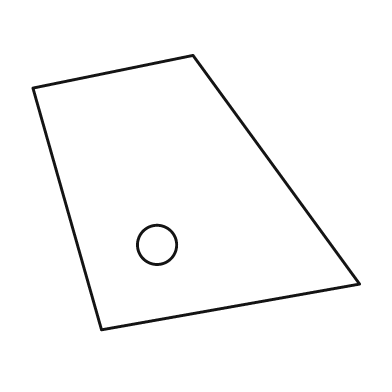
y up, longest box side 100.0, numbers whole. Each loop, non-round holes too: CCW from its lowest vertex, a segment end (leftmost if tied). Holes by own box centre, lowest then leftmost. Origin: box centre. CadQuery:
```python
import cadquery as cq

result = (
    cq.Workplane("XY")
    .moveTo(-29.0, -42.0)
    .lineTo(50.0, -28.0)
    .lineTo(-1.0, 42.0)
    .lineTo(-50.0, 32.0)
    .close()
    .moveTo(-12.0, -16.0)
    .circle(6.0)
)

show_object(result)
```